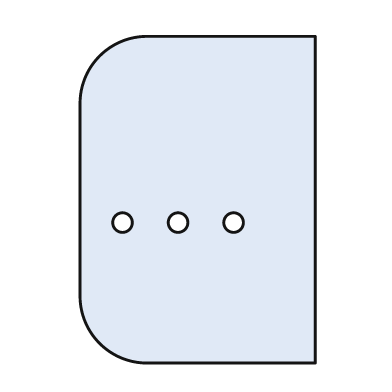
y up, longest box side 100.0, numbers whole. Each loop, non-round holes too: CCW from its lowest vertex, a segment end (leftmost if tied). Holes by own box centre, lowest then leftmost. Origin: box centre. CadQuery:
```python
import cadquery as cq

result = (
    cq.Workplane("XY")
    .moveTo(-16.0, -50.0)
    .lineTo(36.0, -50.0)
    .lineTo(36.0, 50.0)
    .lineTo(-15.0, 50.0)
    .threePointArc((-30.0, 44.0), (-36.0, 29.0))
    .lineTo(-36.0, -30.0)
    .threePointArc((-30.0, -44.0), (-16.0, -50.0))
    .close()
    .moveTo(-23.0, -7.0)
    .circle(3.0)
    .moveTo(-6.0, -7.0)
    .circle(3.0)
    .moveTo(11.0, -7.0)
    .circle(3.0)
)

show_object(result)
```